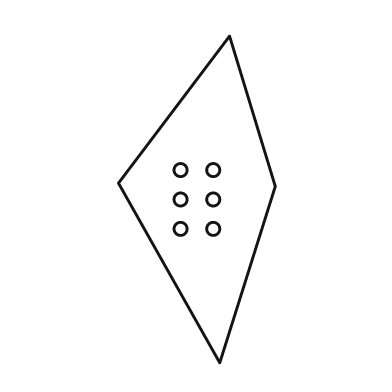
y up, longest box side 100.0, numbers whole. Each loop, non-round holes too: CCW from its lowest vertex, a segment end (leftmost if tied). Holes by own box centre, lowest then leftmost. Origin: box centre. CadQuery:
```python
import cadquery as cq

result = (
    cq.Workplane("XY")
    .moveTo(7.0, -50.0)
    .lineTo(24.0, 4.0)
    .lineTo(10.0, 50.0)
    .lineTo(-24.0, 5.0)
    .close()
    .moveTo(-5.0, -9.0)
    .circle(2.0)
    .moveTo(5.0, -9.0)
    .circle(2.0)
    .moveTo(-5.0, 0.0)
    .circle(2.0)
    .moveTo(5.0, 0.0)
    .circle(2.0)
    .moveTo(-5.0, 9.0)
    .circle(2.0)
    .moveTo(5.0, 9.0)
    .circle(2.0)
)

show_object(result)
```